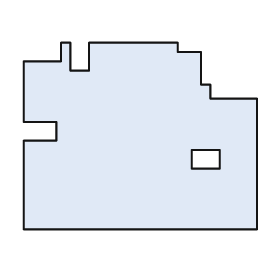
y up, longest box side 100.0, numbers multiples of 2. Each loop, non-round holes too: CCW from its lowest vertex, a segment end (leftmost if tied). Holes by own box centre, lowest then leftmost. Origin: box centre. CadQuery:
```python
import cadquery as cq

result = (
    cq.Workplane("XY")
    .moveTo(-50.0, -40.0)
    .lineTo(50.0, -40.0)
    .lineTo(50.0, 16.0)
    .lineTo(30.0, 16.0)
    .lineTo(30.0, 22.0)
    .lineTo(26.0, 22.0)
    .lineTo(26.0, 36.0)
    .lineTo(16.0, 36.0)
    .lineTo(16.0, 40.0)
    .lineTo(-22.0, 40.0)
    .lineTo(-22.0, 28.0)
    .lineTo(-30.0, 28.0)
    .lineTo(-30.0, 40.0)
    .lineTo(-34.0, 40.0)
    .lineTo(-34.0, 32.0)
    .lineTo(-50.0, 32.0)
    .lineTo(-50.0, 6.0)
    .lineTo(-36.0, 6.0)
    .lineTo(-36.0, -2.0)
    .lineTo(-50.0, -2.0)
    .close()
    .moveTo(22.0, -14.0)
    .lineTo(34.0, -14.0)
    .lineTo(34.0, -6.0)
    .lineTo(22.0, -6.0)
    .close()
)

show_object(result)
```